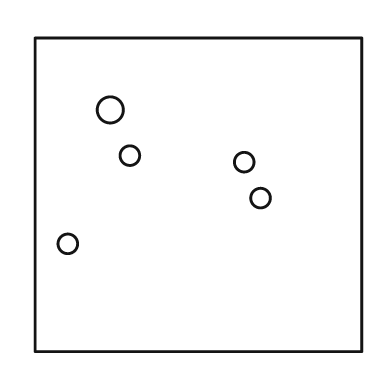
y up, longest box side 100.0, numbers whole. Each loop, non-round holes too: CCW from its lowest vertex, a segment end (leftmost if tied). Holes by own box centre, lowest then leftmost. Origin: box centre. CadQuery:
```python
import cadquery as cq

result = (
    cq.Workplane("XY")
    .moveTo(-50.0, -48.0)
    .lineTo(50.0, -48.0)
    .lineTo(50.0, 48.0)
    .lineTo(-50.0, 48.0)
    .close()
    .moveTo(-40.0, -15.0)
    .circle(3.0)
    .moveTo(19.0, -1.0)
    .circle(3.0)
    .moveTo(14.0, 10.0)
    .circle(3.0)
    .moveTo(-21.0, 12.0)
    .circle(3.0)
    .moveTo(-27.0, 26.0)
    .circle(4.0)
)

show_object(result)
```